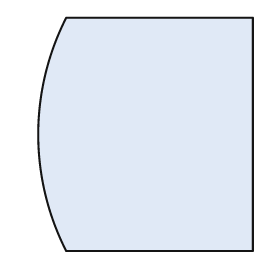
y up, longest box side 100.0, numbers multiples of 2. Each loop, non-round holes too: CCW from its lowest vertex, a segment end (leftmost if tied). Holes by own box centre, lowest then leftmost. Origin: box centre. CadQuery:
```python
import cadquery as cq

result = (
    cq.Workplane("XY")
    .moveTo(-34.0, -50.0)
    .lineTo(46.0, -50.0)
    .lineTo(46.0, 50.0)
    .lineTo(-34.0, 50.0)
    .threePointArc((-46.0, 0.0), (-34.0, -50.0))
    .close()
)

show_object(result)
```